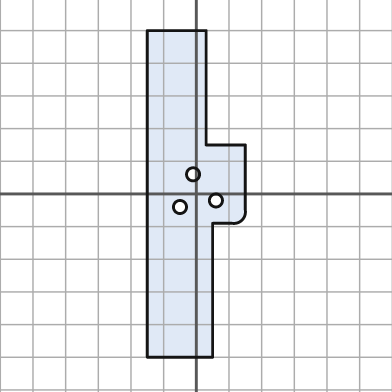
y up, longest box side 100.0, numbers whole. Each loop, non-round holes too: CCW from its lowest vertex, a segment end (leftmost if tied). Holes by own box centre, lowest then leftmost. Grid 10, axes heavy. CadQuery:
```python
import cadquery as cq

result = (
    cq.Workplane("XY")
    .moveTo(-15.0, -50.0)
    .lineTo(5.0, -50.0)
    .lineTo(5.0, -9.0)
    .lineTo(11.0, -9.0)
    .threePointArc((14.0, -8.0), (15.0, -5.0))
    .lineTo(15.0, 15.0)
    .lineTo(3.0, 15.0)
    .lineTo(3.0, 50.0)
    .lineTo(-15.0, 50.0)
    .close()
    .moveTo(-5.0, -4.0)
    .circle(2.0)
    .moveTo(6.0, -2.0)
    .circle(2.0)
    .moveTo(-1.0, 6.0)
    .circle(2.0)
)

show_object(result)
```